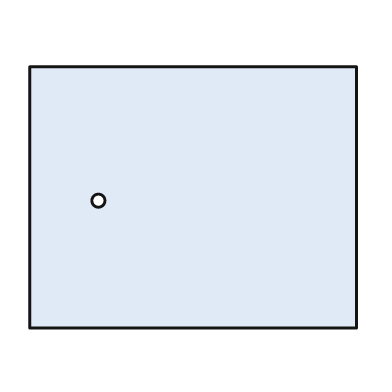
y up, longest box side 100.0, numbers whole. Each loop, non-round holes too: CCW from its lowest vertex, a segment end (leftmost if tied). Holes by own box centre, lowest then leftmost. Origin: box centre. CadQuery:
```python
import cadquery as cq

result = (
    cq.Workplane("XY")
    .moveTo(-50.0, -40.0)
    .lineTo(50.0, -40.0)
    .lineTo(50.0, 40.0)
    .lineTo(-50.0, 40.0)
    .close()
    .moveTo(-29.0, -1.0)
    .circle(2.0)
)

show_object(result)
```